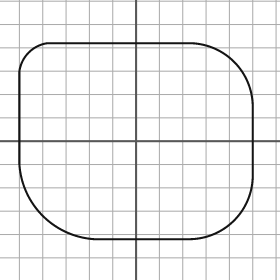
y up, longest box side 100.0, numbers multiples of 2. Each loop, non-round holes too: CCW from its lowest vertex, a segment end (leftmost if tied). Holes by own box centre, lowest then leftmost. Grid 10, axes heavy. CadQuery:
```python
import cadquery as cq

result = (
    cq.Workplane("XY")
    .moveTo(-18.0, -42.0)
    .lineTo(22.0, -42.0)
    .threePointArc((42.0, -34.0), (50.0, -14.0))
    .lineTo(50.0, 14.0)
    .threePointArc((42.0, 34.0), (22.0, 42.0))
    .lineTo(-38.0, 42.0)
    .threePointArc((-46.0, 38.0), (-50.0, 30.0))
    .lineTo(-50.0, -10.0)
    .threePointArc((-40.0, -32.0), (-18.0, -42.0))
    .close()
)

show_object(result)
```